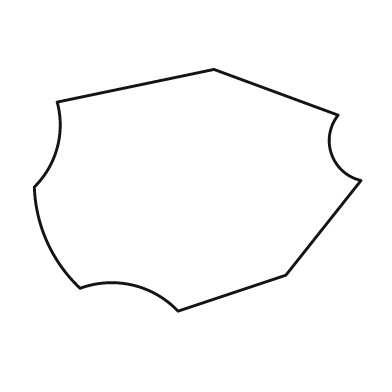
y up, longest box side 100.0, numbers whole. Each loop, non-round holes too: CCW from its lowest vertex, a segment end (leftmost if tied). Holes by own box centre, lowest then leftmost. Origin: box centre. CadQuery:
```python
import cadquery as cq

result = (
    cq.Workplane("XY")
    .moveTo(-6.0, -37.0)
    .lineTo(27.0, -26.0)
    .lineTo(50.0, 3.0)
    .threePointArc((41.0, 11.0), (43.0, 23.0))
    .lineTo(5.0, 37.0)
    .lineTo(-43.0, 27.0)
    .threePointArc((-43.0, 13.0), (-50.0, 1.0))
    .threePointArc((-46.0, -16.0), (-36.0, -30.0))
    .threePointArc((-20.0, -29.0), (-6.0, -37.0))
    .close()
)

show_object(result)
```